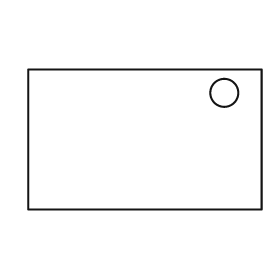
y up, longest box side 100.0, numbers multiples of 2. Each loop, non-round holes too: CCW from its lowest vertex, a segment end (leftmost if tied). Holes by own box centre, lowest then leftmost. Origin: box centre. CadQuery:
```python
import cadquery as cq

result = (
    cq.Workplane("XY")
    .moveTo(-50.0, -30.0)
    .lineTo(50.0, -30.0)
    .lineTo(50.0, 30.0)
    .lineTo(-50.0, 30.0)
    .close()
    .moveTo(34.0, 20.0)
    .circle(6.0)
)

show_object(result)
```